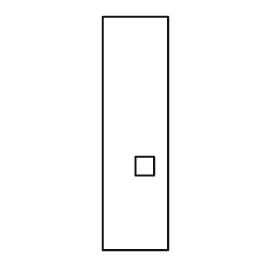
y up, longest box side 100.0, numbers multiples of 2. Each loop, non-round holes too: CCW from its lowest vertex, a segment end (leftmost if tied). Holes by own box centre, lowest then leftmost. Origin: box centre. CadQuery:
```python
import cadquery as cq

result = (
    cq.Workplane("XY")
    .moveTo(-14.0, -50.0)
    .lineTo(14.0, -50.0)
    .lineTo(14.0, 50.0)
    .lineTo(-14.0, 50.0)
    .close()
    .moveTo(0.0, -18.0)
    .lineTo(8.0, -18.0)
    .lineTo(8.0, -10.0)
    .lineTo(0.0, -10.0)
    .close()
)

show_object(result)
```